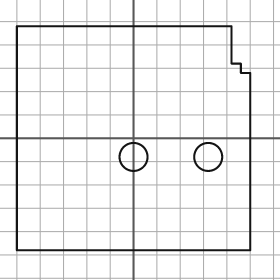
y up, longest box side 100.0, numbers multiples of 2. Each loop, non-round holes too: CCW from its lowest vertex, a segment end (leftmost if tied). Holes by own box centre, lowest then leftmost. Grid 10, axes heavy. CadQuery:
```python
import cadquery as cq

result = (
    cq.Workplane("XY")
    .moveTo(-50.0, -48.0)
    .lineTo(50.0, -48.0)
    .lineTo(50.0, 28.0)
    .lineTo(46.0, 28.0)
    .lineTo(46.0, 32.0)
    .lineTo(42.0, 32.0)
    .lineTo(42.0, 48.0)
    .lineTo(-50.0, 48.0)
    .close()
    .moveTo(0.0, -8.0)
    .circle(6.0)
    .moveTo(32.0, -8.0)
    .circle(6.0)
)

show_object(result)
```